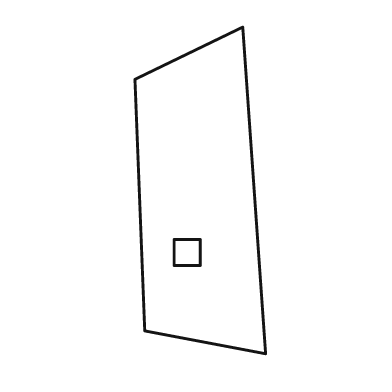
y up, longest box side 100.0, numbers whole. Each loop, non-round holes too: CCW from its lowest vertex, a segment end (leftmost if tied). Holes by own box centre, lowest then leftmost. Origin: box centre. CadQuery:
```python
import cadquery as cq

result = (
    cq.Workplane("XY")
    .moveTo(20.0, -50.0)
    .lineTo(13.0, 50.0)
    .lineTo(-20.0, 34.0)
    .lineTo(-17.0, -43.0)
    .close()
    .moveTo(-8.0, -23.0)
    .lineTo(0.0, -23.0)
    .lineTo(0.0, -15.0)
    .lineTo(-8.0, -15.0)
    .close()
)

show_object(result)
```